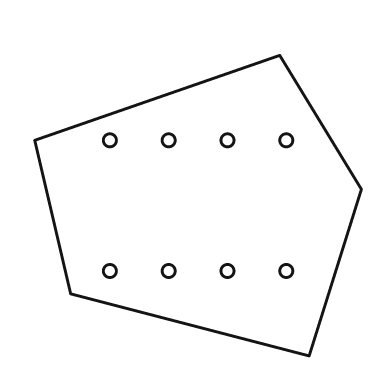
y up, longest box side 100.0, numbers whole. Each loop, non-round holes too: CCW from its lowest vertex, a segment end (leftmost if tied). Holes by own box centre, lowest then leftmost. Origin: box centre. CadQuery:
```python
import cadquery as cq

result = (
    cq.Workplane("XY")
    .moveTo(34.0, -46.0)
    .lineTo(50.0, 5.0)
    .lineTo(25.0, 46.0)
    .lineTo(-50.0, 20.0)
    .lineTo(-39.0, -27.0)
    .close()
    .moveTo(-27.0, -20.0)
    .circle(2.0)
    .moveTo(-9.0, -20.0)
    .circle(2.0)
    .moveTo(9.0, -20.0)
    .circle(2.0)
    .moveTo(27.0, -20.0)
    .circle(2.0)
    .moveTo(-27.0, 20.0)
    .circle(2.0)
    .moveTo(-9.0, 20.0)
    .circle(2.0)
    .moveTo(9.0, 20.0)
    .circle(2.0)
    .moveTo(27.0, 20.0)
    .circle(2.0)
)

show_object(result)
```